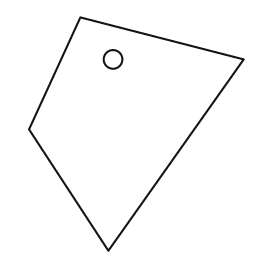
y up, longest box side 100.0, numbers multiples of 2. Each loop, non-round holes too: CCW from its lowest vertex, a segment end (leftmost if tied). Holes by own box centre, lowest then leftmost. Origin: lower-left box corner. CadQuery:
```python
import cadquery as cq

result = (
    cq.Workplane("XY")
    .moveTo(34.0, 0.0)
    .lineTo(92.0, 82.0)
    .lineTo(22.0, 100.0)
    .lineTo(0.0, 52.0)
    .close()
    .moveTo(36.0, 82.0)
    .circle(4.0)
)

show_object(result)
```